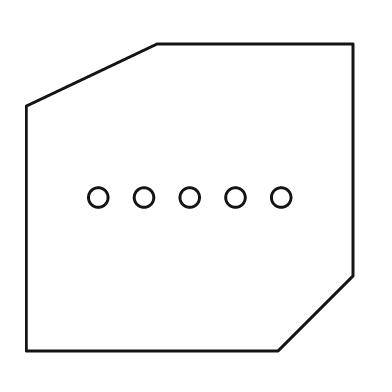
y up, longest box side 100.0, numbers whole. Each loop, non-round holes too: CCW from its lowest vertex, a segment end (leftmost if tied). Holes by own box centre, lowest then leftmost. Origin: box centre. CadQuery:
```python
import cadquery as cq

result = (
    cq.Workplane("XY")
    .moveTo(-50.0, -47.0)
    .lineTo(27.0, -47.0)
    .lineTo(50.0, -24.0)
    .lineTo(50.0, 47.0)
    .lineTo(-10.0, 47.0)
    .lineTo(-50.0, 28.0)
    .close()
    .moveTo(-28.0, 0.0)
    .circle(3.0)
    .moveTo(-14.0, 0.0)
    .circle(3.0)
    .moveTo(0.0, 0.0)
    .circle(3.0)
    .moveTo(14.0, 0.0)
    .circle(3.0)
    .moveTo(28.0, 0.0)
    .circle(3.0)
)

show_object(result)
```